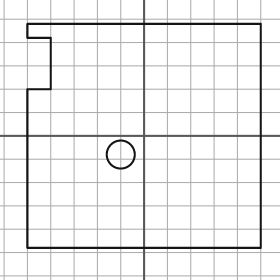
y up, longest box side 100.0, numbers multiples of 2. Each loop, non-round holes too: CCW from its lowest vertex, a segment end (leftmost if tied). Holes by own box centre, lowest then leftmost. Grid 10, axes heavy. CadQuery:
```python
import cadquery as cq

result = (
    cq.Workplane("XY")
    .moveTo(-50.0, -48.0)
    .lineTo(50.0, -48.0)
    .lineTo(50.0, 48.0)
    .lineTo(-50.0, 48.0)
    .lineTo(-50.0, 42.0)
    .lineTo(-40.0, 42.0)
    .lineTo(-40.0, 20.0)
    .lineTo(-50.0, 20.0)
    .close()
    .moveTo(-10.0, -8.0)
    .circle(6.0)
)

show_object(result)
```